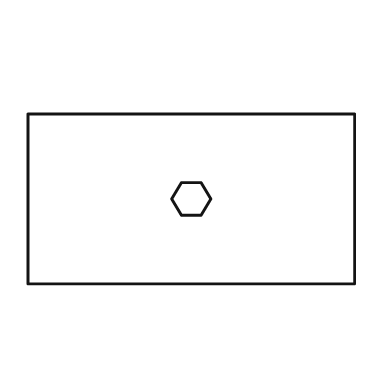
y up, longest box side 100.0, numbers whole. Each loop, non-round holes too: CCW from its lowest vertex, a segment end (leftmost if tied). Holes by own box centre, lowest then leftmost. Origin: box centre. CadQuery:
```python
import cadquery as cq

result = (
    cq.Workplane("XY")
    .moveTo(-50.0, -26.0)
    .lineTo(50.0, -26.0)
    .lineTo(50.0, 26.0)
    .lineTo(-50.0, 26.0)
    .close()
    .moveTo(-3.0, -5.0)
    .lineTo(3.0, -5.0)
    .lineTo(6.0, 0.0)
    .lineTo(3.0, 5.0)
    .lineTo(-3.0, 5.0)
    .lineTo(-6.0, 0.0)
    .close()
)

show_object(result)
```